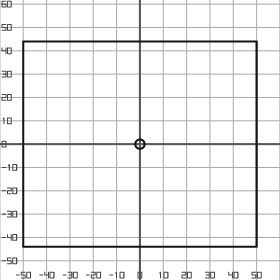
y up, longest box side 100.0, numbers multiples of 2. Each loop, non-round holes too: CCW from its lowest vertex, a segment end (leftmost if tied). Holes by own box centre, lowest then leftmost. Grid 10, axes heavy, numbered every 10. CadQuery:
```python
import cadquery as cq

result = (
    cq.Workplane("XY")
    .moveTo(-50.0, -44.0)
    .lineTo(50.0, -44.0)
    .lineTo(50.0, 44.0)
    .lineTo(-50.0, 44.0)
    .close()
    .moveTo(0.0, 0.0)
    .circle(2.0)
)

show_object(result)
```